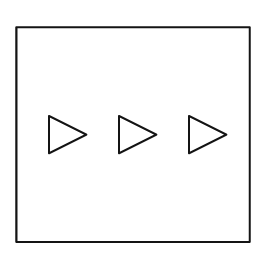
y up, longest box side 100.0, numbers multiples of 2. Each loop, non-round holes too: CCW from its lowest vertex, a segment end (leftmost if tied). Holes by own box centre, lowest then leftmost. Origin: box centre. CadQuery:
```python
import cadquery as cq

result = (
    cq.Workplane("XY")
    .moveTo(-50.0, -46.0)
    .lineTo(50.0, -46.0)
    .lineTo(50.0, 46.0)
    .lineTo(-50.0, 46.0)
    .close()
    .moveTo(-36.0, -8.0)
    .lineTo(-20.0, 0.0)
    .lineTo(-36.0, 8.0)
    .close()
    .moveTo(-6.0, -8.0)
    .lineTo(10.0, 0.0)
    .lineTo(-6.0, 8.0)
    .close()
    .moveTo(24.0, -8.0)
    .lineTo(40.0, 0.0)
    .lineTo(24.0, 8.0)
    .close()
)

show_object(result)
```